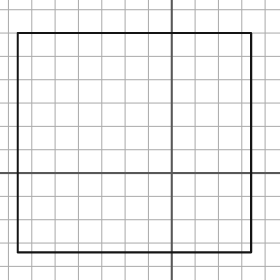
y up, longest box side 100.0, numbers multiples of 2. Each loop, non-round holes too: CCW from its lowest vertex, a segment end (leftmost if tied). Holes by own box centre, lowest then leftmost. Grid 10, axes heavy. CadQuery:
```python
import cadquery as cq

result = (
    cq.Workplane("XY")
    .moveTo(-66.0, -34.0)
    .lineTo(34.0, -34.0)
    .lineTo(34.0, 60.0)
    .lineTo(-66.0, 60.0)
    .close()
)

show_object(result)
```